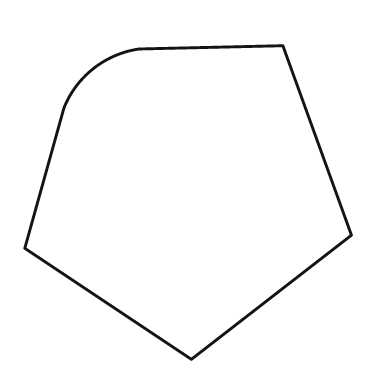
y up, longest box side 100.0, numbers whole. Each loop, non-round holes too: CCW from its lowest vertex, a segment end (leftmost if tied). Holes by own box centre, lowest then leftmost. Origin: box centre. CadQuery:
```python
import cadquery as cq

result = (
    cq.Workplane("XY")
    .moveTo(1.0, -48.0)
    .lineTo(50.0, -10.0)
    .lineTo(29.0, 48.0)
    .lineTo(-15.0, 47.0)
    .threePointArc((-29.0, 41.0), (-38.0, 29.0))
    .lineTo(-50.0, -14.0)
    .close()
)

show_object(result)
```